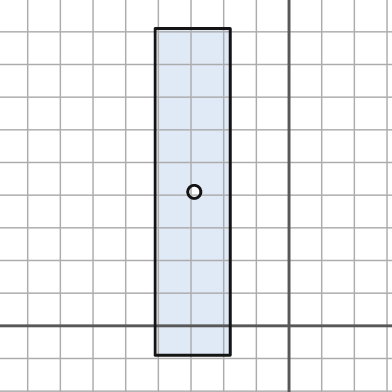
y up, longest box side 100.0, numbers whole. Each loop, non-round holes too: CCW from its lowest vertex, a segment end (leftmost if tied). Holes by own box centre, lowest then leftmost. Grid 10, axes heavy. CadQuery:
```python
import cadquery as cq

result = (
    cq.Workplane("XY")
    .moveTo(-41.0, -9.0)
    .lineTo(-18.0, -9.0)
    .lineTo(-18.0, 91.0)
    .lineTo(-41.0, 91.0)
    .close()
    .moveTo(-29.0, 41.0)
    .circle(2.0)
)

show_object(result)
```